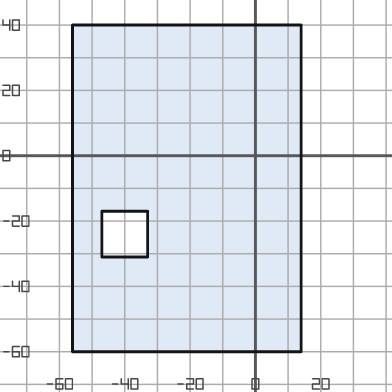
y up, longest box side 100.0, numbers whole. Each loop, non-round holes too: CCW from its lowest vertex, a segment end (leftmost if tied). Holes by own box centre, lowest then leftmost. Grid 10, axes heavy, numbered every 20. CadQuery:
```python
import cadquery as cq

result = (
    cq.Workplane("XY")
    .moveTo(-56.0, -60.0)
    .lineTo(14.0, -60.0)
    .lineTo(14.0, 40.0)
    .lineTo(-56.0, 40.0)
    .close()
    .moveTo(-47.0, -31.0)
    .lineTo(-33.0, -31.0)
    .lineTo(-33.0, -17.0)
    .lineTo(-47.0, -17.0)
    .close()
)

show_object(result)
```